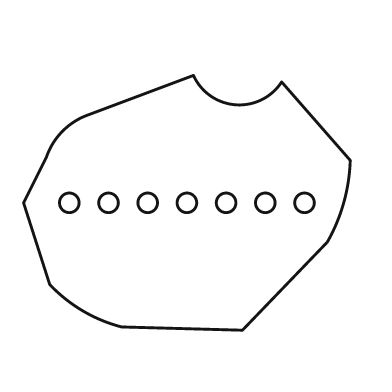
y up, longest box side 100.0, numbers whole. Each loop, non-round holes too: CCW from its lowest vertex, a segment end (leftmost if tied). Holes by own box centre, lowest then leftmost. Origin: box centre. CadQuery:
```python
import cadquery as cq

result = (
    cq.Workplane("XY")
    .moveTo(17.0, -39.0)
    .lineTo(43.0, -12.0)
    .threePointArc((48.0, 0.0), (50.0, 13.0))
    .lineTo(29.0, 37.0)
    .threePointArc((15.0, 30.0), (2.0, 39.0))
    .lineTo(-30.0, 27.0)
    .threePointArc((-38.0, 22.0), (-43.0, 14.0))
    .lineTo(-50.0, 0.0)
    .lineTo(-42.0, -25.0)
    .threePointArc((-32.0, -33.0), (-20.0, -38.0))
    .close()
    .moveTo(-36.0, 0.0)
    .circle(3.0)
    .moveTo(-24.0, 0.0)
    .circle(3.0)
    .moveTo(-12.0, 0.0)
    .circle(3.0)
    .moveTo(0.0, 0.0)
    .circle(3.0)
    .moveTo(12.0, 0.0)
    .circle(3.0)
    .moveTo(24.0, 0.0)
    .circle(3.0)
    .moveTo(36.0, 0.0)
    .circle(3.0)
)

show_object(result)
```